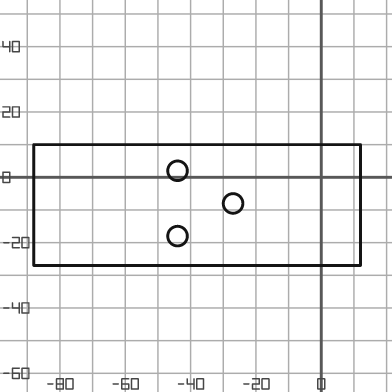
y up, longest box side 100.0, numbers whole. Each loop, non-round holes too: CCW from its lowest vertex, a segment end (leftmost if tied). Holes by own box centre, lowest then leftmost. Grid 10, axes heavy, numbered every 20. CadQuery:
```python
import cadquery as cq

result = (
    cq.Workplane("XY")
    .moveTo(-88.0, -27.0)
    .lineTo(12.0, -27.0)
    .lineTo(12.0, 10.0)
    .lineTo(-88.0, 10.0)
    .close()
    .moveTo(-44.0, -18.0)
    .circle(3.0)
    .moveTo(-27.0, -8.0)
    .circle(3.0)
    .moveTo(-44.0, 2.0)
    .circle(3.0)
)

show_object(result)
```